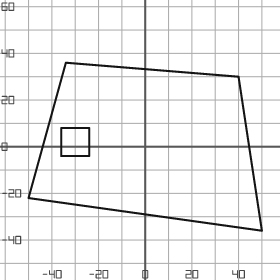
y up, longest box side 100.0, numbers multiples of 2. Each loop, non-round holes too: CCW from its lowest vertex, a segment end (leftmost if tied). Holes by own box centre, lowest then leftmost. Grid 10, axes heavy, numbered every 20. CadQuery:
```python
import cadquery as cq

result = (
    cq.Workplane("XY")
    .moveTo(50.0, -36.0)
    .lineTo(40.0, 30.0)
    .lineTo(-34.0, 36.0)
    .lineTo(-50.0, -22.0)
    .close()
    .moveTo(-36.0, -4.0)
    .lineTo(-24.0, -4.0)
    .lineTo(-24.0, 8.0)
    .lineTo(-36.0, 8.0)
    .close()
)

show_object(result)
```